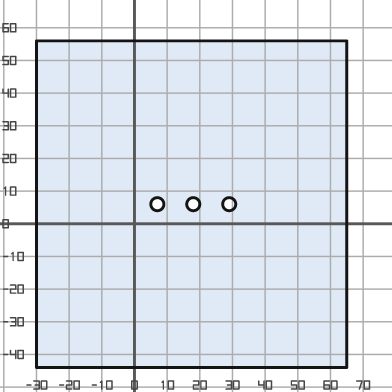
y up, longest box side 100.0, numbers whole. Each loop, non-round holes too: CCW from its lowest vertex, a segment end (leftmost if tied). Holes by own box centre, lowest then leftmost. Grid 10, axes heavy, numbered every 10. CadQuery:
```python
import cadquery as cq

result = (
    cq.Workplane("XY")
    .moveTo(-30.0, -44.0)
    .lineTo(65.0, -44.0)
    .lineTo(65.0, 56.0)
    .lineTo(-30.0, 56.0)
    .close()
    .moveTo(7.0, 6.0)
    .circle(2.0)
    .moveTo(18.0, 6.0)
    .circle(2.0)
    .moveTo(29.0, 6.0)
    .circle(2.0)
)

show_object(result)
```